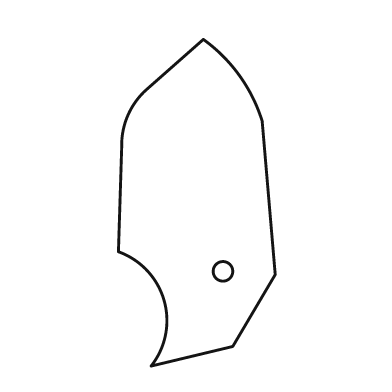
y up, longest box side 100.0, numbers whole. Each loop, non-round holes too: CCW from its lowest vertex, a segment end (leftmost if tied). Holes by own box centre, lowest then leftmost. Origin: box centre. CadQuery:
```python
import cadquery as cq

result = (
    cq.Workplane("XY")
    .moveTo(-14.0, -50.0)
    .lineTo(11.0, -44.0)
    .lineTo(24.0, -22.0)
    .lineTo(20.0, 25.0)
    .threePointArc((13.0, 39.0), (2.0, 50.0))
    .lineTo(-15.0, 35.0)
    .threePointArc((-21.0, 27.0), (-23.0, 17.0))
    .lineTo(-24.0, -15.0)
    .threePointArc((-10.0, -30.0), (-14.0, -50.0))
    .close()
    .moveTo(8.0, -21.0)
    .circle(3.0)
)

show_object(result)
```